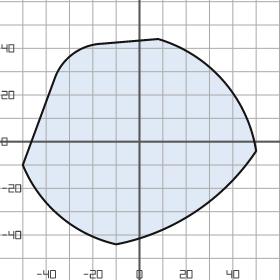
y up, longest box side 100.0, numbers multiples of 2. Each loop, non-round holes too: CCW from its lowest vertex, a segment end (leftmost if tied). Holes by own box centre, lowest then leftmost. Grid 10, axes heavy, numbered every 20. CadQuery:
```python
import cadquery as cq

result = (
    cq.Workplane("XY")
    .moveTo(-10.0, -44.0)
    .threePointArc((24.0, -30.0), (50.0, -4.0))
    .threePointArc((36.0, 26.0), (8.0, 44.0))
    .lineTo(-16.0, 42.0)
    .threePointArc((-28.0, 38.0), (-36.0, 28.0))
    .lineTo(-50.0, -10.0)
    .threePointArc((-34.0, -32.0), (-10.0, -44.0))
    .close()
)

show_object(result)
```